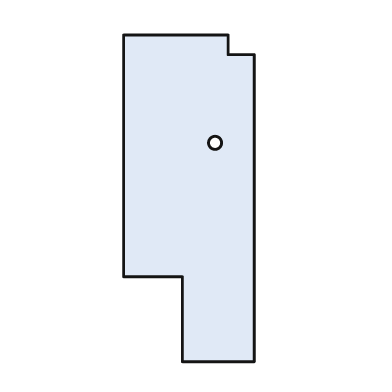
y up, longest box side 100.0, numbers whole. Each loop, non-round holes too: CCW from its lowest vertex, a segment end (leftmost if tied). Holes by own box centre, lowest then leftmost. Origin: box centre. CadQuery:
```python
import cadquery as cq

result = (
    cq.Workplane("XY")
    .moveTo(-2.0, -50.0)
    .lineTo(20.0, -50.0)
    .lineTo(20.0, 44.0)
    .lineTo(12.0, 44.0)
    .lineTo(12.0, 50.0)
    .lineTo(-20.0, 50.0)
    .lineTo(-20.0, -24.0)
    .lineTo(-2.0, -24.0)
    .close()
    .moveTo(8.0, 17.0)
    .circle(2.0)
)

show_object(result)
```